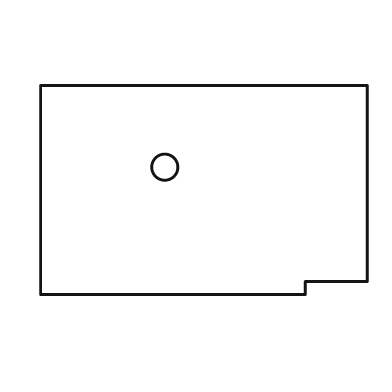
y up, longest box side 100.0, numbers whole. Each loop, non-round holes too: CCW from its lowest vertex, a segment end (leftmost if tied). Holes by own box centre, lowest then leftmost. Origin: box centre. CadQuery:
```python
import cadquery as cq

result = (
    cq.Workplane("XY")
    .moveTo(-50.0, -32.0)
    .lineTo(31.0, -32.0)
    .lineTo(31.0, -28.0)
    .lineTo(50.0, -28.0)
    .lineTo(50.0, 32.0)
    .lineTo(-50.0, 32.0)
    .close()
    .moveTo(-12.0, 7.0)
    .circle(4.0)
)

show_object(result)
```